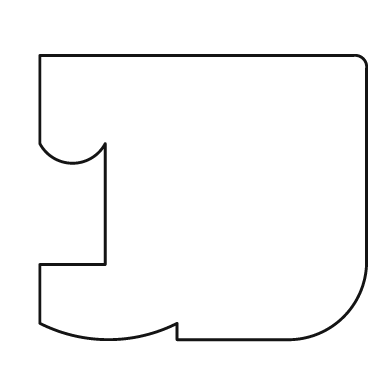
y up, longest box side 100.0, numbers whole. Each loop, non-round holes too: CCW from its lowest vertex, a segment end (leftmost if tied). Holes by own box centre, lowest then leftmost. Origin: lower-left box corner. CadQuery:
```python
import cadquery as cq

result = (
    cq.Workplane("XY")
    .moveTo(42.0, 0.0)
    .lineTo(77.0, 0.0)
    .threePointArc((93.0, 7.0), (100.0, 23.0))
    .lineTo(100.0, 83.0)
    .threePointArc((99.0, 86.0), (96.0, 87.0))
    .lineTo(0.0, 87.0)
    .lineTo(0.0, 60.0)
    .threePointArc((10.0, 54.0), (20.0, 60.0))
    .lineTo(20.0, 23.0)
    .lineTo(0.0, 23.0)
    .lineTo(0.0, 5.0)
    .threePointArc((21.0, 0.0), (42.0, 5.0))
    .close()
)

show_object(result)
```